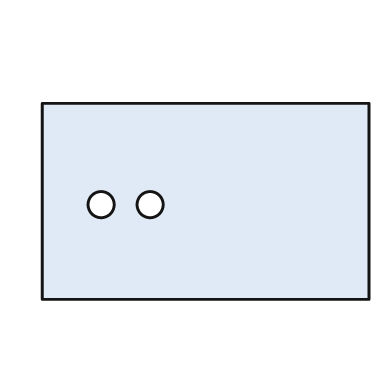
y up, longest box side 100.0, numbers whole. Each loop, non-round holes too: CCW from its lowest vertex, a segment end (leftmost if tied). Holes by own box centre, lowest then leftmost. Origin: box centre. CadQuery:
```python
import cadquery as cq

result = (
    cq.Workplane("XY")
    .moveTo(-50.0, -30.0)
    .lineTo(50.0, -30.0)
    .lineTo(50.0, 30.0)
    .lineTo(-50.0, 30.0)
    .close()
    .moveTo(-32.0, -1.0)
    .circle(4.0)
    .moveTo(-17.0, -1.0)
    .circle(4.0)
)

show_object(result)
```